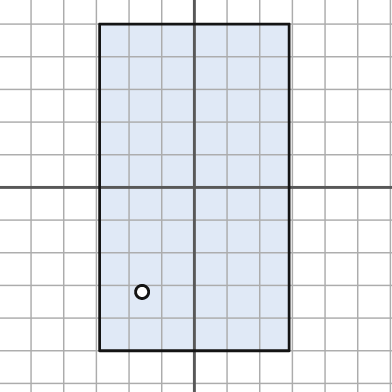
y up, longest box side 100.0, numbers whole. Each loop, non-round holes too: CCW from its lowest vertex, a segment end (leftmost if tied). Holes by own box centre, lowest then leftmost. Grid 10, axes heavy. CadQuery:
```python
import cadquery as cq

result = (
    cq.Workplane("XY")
    .moveTo(-29.0, -50.0)
    .lineTo(29.0, -50.0)
    .lineTo(29.0, 50.0)
    .lineTo(-29.0, 50.0)
    .close()
    .moveTo(-16.0, -32.0)
    .circle(2.0)
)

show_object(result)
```